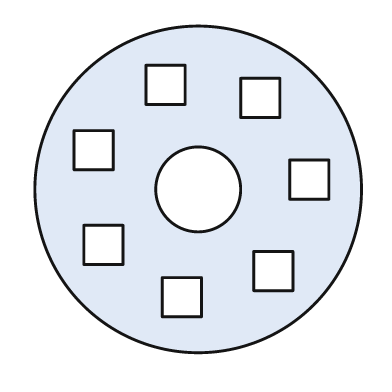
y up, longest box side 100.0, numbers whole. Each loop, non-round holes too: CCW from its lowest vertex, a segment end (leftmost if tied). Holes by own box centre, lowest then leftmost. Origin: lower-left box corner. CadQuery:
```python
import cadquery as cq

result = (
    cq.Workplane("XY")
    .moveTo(50.0, 50.0)
    .circle(50.0)
    .moveTo(39.0, 11.0)
    .lineTo(51.0, 11.0)
    .lineTo(51.0, 23.0)
    .lineTo(39.0, 23.0)
    .close()
    .moveTo(67.0, 19.0)
    .lineTo(79.0, 19.0)
    .lineTo(79.0, 31.0)
    .lineTo(67.0, 31.0)
    .close()
    .moveTo(15.0, 27.0)
    .lineTo(27.0, 27.0)
    .lineTo(27.0, 39.0)
    .lineTo(15.0, 39.0)
    .close()
    .moveTo(50.0, 50.0)
    .circle(13.0)
    .moveTo(78.0, 47.0)
    .lineTo(90.0, 47.0)
    .lineTo(90.0, 59.0)
    .lineTo(78.0, 59.0)
    .close()
    .moveTo(12.0, 56.0)
    .lineTo(24.0, 56.0)
    .lineTo(24.0, 68.0)
    .lineTo(12.0, 68.0)
    .close()
    .moveTo(63.0, 72.0)
    .lineTo(75.0, 72.0)
    .lineTo(75.0, 84.0)
    .lineTo(63.0, 84.0)
    .close()
    .moveTo(34.0, 76.0)
    .lineTo(46.0, 76.0)
    .lineTo(46.0, 88.0)
    .lineTo(34.0, 88.0)
    .close()
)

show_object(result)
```